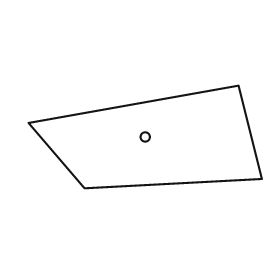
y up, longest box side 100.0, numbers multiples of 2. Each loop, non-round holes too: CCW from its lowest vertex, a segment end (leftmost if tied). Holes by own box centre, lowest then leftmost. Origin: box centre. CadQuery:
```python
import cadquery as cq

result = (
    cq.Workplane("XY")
    .moveTo(-26.0, -22.0)
    .lineTo(50.0, -18.0)
    .lineTo(40.0, 22.0)
    .lineTo(-50.0, 6.0)
    .close()
    .moveTo(0.0, 0.0)
    .circle(2.0)
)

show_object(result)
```